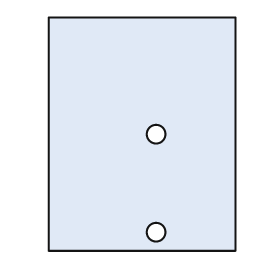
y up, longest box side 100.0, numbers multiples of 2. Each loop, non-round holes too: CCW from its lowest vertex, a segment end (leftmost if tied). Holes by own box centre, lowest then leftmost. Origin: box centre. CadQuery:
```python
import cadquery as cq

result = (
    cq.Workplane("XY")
    .moveTo(-40.0, -50.0)
    .lineTo(40.0, -50.0)
    .lineTo(40.0, 50.0)
    .lineTo(-40.0, 50.0)
    .close()
    .moveTo(6.0, -42.0)
    .circle(4.0)
    .moveTo(6.0, 0.0)
    .circle(4.0)
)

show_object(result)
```